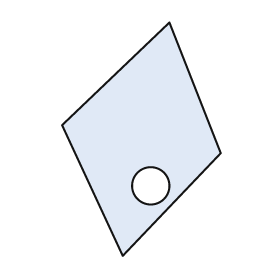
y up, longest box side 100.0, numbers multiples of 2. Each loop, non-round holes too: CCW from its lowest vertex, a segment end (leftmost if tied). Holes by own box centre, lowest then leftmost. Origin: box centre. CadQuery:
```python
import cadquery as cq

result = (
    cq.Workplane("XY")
    .moveTo(-8.0, -50.0)
    .lineTo(34.0, -6.0)
    .lineTo(12.0, 50.0)
    .lineTo(-34.0, 6.0)
    .close()
    .moveTo(4.0, -20.0)
    .circle(8.0)
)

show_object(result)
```